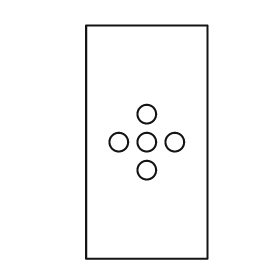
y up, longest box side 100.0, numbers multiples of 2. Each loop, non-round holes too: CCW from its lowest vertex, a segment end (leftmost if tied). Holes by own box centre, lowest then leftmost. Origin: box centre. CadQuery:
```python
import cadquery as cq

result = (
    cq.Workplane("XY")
    .moveTo(-26.0, -50.0)
    .lineTo(26.0, -50.0)
    .lineTo(26.0, 50.0)
    .lineTo(-26.0, 50.0)
    .close()
    .moveTo(0.0, -12.0)
    .circle(4.0)
    .moveTo(-12.0, 0.0)
    .circle(4.0)
    .moveTo(0.0, 0.0)
    .circle(4.0)
    .moveTo(12.0, 0.0)
    .circle(4.0)
    .moveTo(0.0, 12.0)
    .circle(4.0)
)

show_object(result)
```